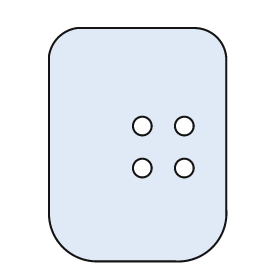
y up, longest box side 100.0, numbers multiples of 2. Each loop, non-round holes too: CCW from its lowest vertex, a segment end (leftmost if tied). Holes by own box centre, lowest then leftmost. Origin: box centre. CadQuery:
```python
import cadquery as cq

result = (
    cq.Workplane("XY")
    .moveTo(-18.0, -50.0)
    .lineTo(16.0, -50.0)
    .threePointArc((32.0, -44.0), (38.0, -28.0))
    .lineTo(38.0, 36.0)
    .threePointArc((34.0, 46.0), (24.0, 50.0))
    .lineTo(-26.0, 50.0)
    .threePointArc((-34.0, 46.0), (-38.0, 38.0))
    .lineTo(-38.0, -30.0)
    .threePointArc((-32.0, -44.0), (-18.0, -50.0))
    .close()
    .moveTo(2.0, -10.0)
    .circle(4.0)
    .moveTo(20.0, -10.0)
    .circle(4.0)
    .moveTo(2.0, 8.0)
    .circle(4.0)
    .moveTo(20.0, 8.0)
    .circle(4.0)
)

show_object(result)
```